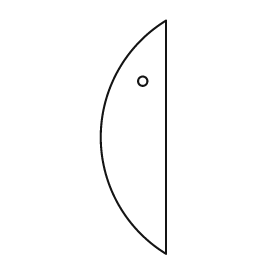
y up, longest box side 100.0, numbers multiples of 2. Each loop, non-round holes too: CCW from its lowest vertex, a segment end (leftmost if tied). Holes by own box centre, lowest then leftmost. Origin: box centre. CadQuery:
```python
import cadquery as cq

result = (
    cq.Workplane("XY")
    .moveTo(14.0, -50.0)
    .lineTo(14.0, 50.0)
    .threePointArc((-14.0, 0.0), (14.0, -50.0))
    .close()
    .moveTo(4.0, 24.0)
    .circle(2.0)
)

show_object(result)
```